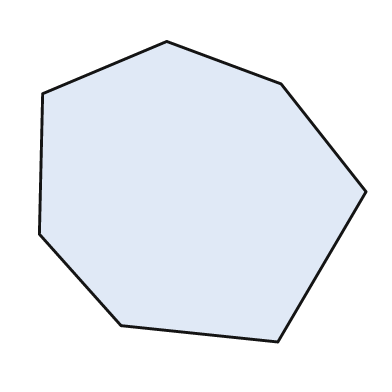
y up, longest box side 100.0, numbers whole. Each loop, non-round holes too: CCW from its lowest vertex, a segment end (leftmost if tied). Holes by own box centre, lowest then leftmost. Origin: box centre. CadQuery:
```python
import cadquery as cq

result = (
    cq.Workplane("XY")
    .moveTo(23.0, -46.0)
    .lineTo(50.0, 0.0)
    .lineTo(24.0, 33.0)
    .lineTo(-11.0, 46.0)
    .lineTo(-49.0, 30.0)
    .lineTo(-50.0, -13.0)
    .lineTo(-25.0, -41.0)
    .close()
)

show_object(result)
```